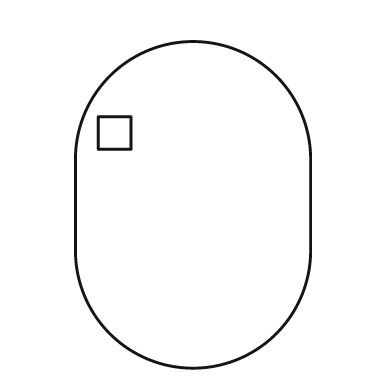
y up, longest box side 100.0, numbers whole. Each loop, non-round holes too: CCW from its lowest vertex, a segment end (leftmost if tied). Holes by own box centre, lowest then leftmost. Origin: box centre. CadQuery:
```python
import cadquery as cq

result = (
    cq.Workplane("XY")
    .moveTo(-36.0, -14.0)
    .threePointArc((0.0, -50.0), (36.0, -14.0))
    .lineTo(36.0, 14.0)
    .threePointArc((0.0, 50.0), (-36.0, 14.0))
    .close()
    .moveTo(-29.0, 17.0)
    .lineTo(-19.0, 17.0)
    .lineTo(-19.0, 27.0)
    .lineTo(-29.0, 27.0)
    .close()
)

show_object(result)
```